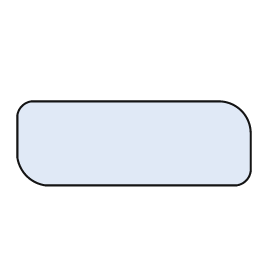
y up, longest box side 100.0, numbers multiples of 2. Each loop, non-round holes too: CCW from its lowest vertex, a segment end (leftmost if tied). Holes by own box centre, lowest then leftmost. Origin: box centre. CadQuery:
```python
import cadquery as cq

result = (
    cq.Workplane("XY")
    .moveTo(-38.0, -18.0)
    .lineTo(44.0, -18.0)
    .threePointArc((48.0, -16.0), (50.0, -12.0))
    .lineTo(50.0, 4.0)
    .threePointArc((46.0, 14.0), (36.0, 18.0))
    .lineTo(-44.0, 18.0)
    .threePointArc((-48.0, 16.0), (-50.0, 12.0))
    .lineTo(-50.0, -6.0)
    .threePointArc((-46.0, -14.0), (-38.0, -18.0))
    .close()
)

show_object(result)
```